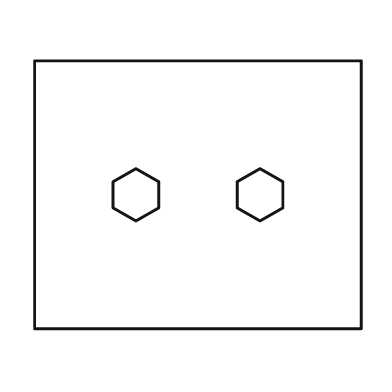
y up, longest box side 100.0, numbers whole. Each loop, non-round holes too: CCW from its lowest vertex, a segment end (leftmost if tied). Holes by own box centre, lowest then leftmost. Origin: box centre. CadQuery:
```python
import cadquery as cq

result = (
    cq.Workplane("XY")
    .moveTo(-50.0, -41.0)
    .lineTo(50.0, -41.0)
    .lineTo(50.0, 41.0)
    .lineTo(-50.0, 41.0)
    .close()
    .moveTo(-19.0, -8.0)
    .lineTo(-12.0, -4.0)
    .lineTo(-12.0, 4.0)
    .lineTo(-19.0, 8.0)
    .lineTo(-26.0, 4.0)
    .lineTo(-26.0, -4.0)
    .close()
    .moveTo(19.0, -8.0)
    .lineTo(26.0, -4.0)
    .lineTo(26.0, 4.0)
    .lineTo(19.0, 8.0)
    .lineTo(12.0, 4.0)
    .lineTo(12.0, -4.0)
    .close()
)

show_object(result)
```